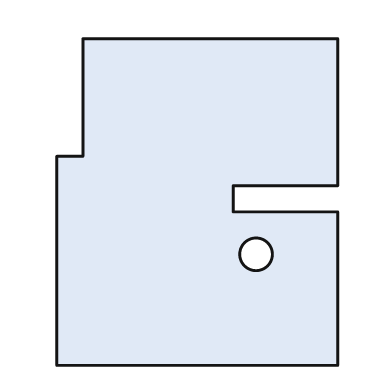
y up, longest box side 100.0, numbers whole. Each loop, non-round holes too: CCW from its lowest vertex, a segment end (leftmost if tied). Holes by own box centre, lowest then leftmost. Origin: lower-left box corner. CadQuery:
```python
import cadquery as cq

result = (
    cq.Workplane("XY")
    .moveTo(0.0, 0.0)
    .lineTo(86.0, 0.0)
    .lineTo(86.0, 47.0)
    .lineTo(54.0, 47.0)
    .lineTo(54.0, 55.0)
    .lineTo(86.0, 55.0)
    .lineTo(86.0, 100.0)
    .lineTo(8.0, 100.0)
    .lineTo(8.0, 64.0)
    .lineTo(0.0, 64.0)
    .close()
    .moveTo(61.0, 34.0)
    .circle(5.0)
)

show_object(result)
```